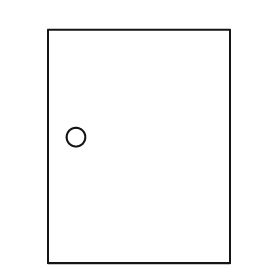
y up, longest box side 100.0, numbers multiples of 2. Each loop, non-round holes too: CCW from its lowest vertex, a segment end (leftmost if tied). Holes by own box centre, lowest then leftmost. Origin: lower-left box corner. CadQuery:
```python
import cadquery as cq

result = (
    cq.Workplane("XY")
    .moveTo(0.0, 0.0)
    .lineTo(78.0, 0.0)
    .lineTo(78.0, 100.0)
    .lineTo(0.0, 100.0)
    .close()
    .moveTo(12.0, 54.0)
    .circle(4.0)
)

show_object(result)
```